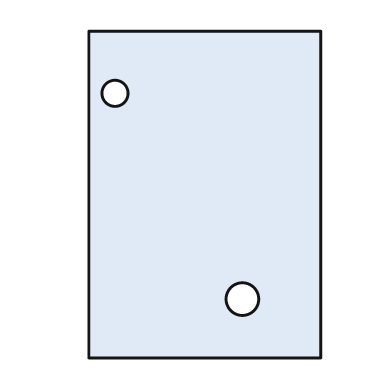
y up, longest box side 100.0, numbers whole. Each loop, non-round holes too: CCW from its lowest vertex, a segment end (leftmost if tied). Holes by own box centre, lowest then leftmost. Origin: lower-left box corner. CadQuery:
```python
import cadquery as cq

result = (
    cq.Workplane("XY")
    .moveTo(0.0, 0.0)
    .lineTo(71.0, 0.0)
    .lineTo(71.0, 100.0)
    .lineTo(0.0, 100.0)
    .close()
    .moveTo(47.0, 18.0)
    .circle(5.0)
    .moveTo(8.0, 81.0)
    .circle(4.0)
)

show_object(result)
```